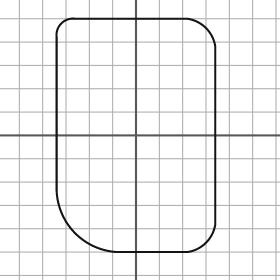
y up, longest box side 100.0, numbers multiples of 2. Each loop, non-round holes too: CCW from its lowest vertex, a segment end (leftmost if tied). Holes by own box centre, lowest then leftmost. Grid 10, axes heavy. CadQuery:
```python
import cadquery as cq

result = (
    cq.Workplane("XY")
    .moveTo(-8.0, -50.0)
    .lineTo(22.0, -50.0)
    .threePointArc((30.0, -46.0), (34.0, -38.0))
    .lineTo(34.0, 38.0)
    .threePointArc((30.0, 46.0), (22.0, 50.0))
    .lineTo(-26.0, 50.0)
    .threePointArc((-32.0, 48.0), (-34.0, 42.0))
    .lineTo(-34.0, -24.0)
    .threePointArc((-26.0, -42.0), (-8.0, -50.0))
    .close()
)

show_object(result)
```